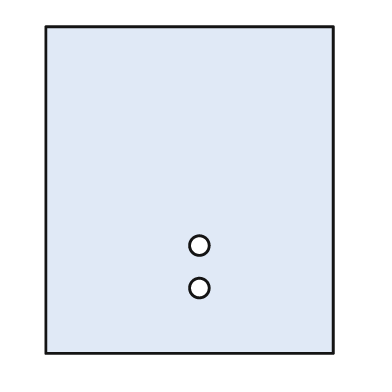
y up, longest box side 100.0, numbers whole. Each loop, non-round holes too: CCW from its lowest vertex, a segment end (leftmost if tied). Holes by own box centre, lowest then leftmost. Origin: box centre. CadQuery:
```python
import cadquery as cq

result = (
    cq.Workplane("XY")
    .moveTo(-44.0, -50.0)
    .lineTo(44.0, -50.0)
    .lineTo(44.0, 50.0)
    .lineTo(-44.0, 50.0)
    .close()
    .moveTo(3.0, -30.0)
    .circle(3.0)
    .moveTo(3.0, -17.0)
    .circle(3.0)
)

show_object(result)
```